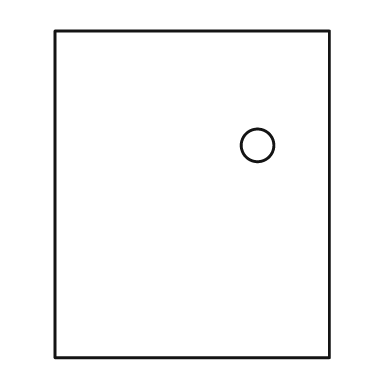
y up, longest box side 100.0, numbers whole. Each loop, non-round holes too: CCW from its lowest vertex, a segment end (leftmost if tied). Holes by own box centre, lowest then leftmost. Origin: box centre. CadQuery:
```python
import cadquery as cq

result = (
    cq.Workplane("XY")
    .moveTo(-42.0, -50.0)
    .lineTo(42.0, -50.0)
    .lineTo(42.0, 50.0)
    .lineTo(-42.0, 50.0)
    .close()
    .moveTo(20.0, 15.0)
    .circle(5.0)
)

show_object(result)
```